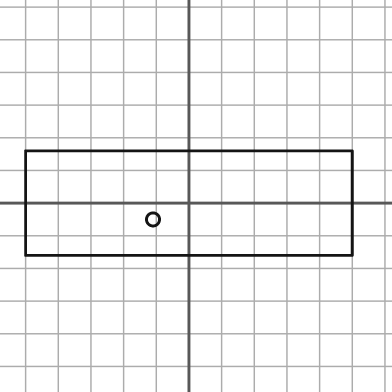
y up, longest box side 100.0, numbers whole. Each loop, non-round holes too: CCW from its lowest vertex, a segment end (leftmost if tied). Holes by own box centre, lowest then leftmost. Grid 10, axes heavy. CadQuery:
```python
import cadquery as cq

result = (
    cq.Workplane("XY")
    .moveTo(-50.0, -16.0)
    .lineTo(50.0, -16.0)
    .lineTo(50.0, 16.0)
    .lineTo(-50.0, 16.0)
    .close()
    .moveTo(-11.0, -5.0)
    .circle(2.0)
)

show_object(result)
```